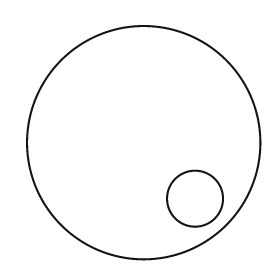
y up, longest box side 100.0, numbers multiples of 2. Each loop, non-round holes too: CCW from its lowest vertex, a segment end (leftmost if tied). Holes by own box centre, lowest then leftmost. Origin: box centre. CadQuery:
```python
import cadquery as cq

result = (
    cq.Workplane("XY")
    .moveTo(0.0, 0.0)
    .circle(50.0)
    .moveTo(22.0, -24.0)
    .circle(12.0)
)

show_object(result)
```